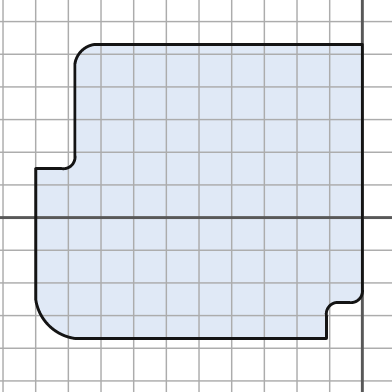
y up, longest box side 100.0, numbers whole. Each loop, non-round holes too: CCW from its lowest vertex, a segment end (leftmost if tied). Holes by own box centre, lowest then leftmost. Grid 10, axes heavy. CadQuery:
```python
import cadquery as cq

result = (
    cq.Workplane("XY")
    .moveTo(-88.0, -37.0)
    .lineTo(-11.0, -37.0)
    .lineTo(-11.0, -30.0)
    .threePointArc((-10.0, -27.0), (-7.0, -26.0))
    .lineTo(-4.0, -26.0)
    .threePointArc((-1.0, -25.0), (0.0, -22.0))
    .lineTo(0.0, 53.0)
    .lineTo(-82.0, 53.0)
    .threePointArc((-86.0, 51.0), (-88.0, 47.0))
    .lineTo(-88.0, 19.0)
    .threePointArc((-89.0, 16.0), (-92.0, 15.0))
    .lineTo(-100.0, 15.0)
    .lineTo(-100.0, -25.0)
    .threePointArc((-96.0, -33.0), (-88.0, -37.0))
    .close()
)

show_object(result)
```